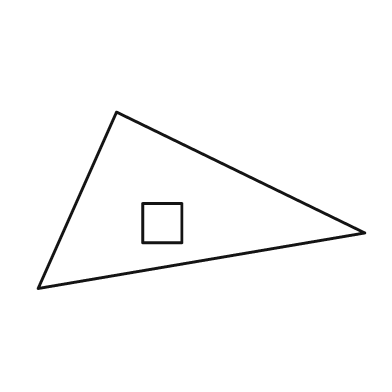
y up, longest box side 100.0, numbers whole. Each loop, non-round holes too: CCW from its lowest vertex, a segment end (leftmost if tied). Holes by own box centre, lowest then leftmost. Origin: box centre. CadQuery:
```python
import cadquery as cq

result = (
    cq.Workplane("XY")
    .moveTo(-50.0, -27.0)
    .lineTo(50.0, -10.0)
    .lineTo(-26.0, 27.0)
    .close()
    .moveTo(-18.0, -13.0)
    .lineTo(-6.0, -13.0)
    .lineTo(-6.0, -1.0)
    .lineTo(-18.0, -1.0)
    .close()
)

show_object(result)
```